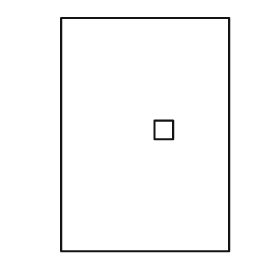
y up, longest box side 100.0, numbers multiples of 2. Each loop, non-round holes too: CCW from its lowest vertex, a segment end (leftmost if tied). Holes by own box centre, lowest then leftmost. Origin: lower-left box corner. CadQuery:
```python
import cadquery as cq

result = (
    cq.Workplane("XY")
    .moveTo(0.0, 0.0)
    .lineTo(72.0, 0.0)
    .lineTo(72.0, 100.0)
    .lineTo(0.0, 100.0)
    .close()
    .moveTo(40.0, 48.0)
    .lineTo(48.0, 48.0)
    .lineTo(48.0, 56.0)
    .lineTo(40.0, 56.0)
    .close()
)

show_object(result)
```